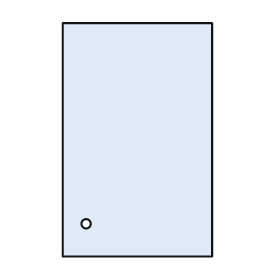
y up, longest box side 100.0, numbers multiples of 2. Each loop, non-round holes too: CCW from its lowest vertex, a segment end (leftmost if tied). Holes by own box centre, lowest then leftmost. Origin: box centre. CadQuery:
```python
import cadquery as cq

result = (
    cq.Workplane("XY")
    .moveTo(-32.0, -50.0)
    .lineTo(32.0, -50.0)
    .lineTo(32.0, 50.0)
    .lineTo(-32.0, 50.0)
    .close()
    .moveTo(-22.0, -36.0)
    .circle(2.0)
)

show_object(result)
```